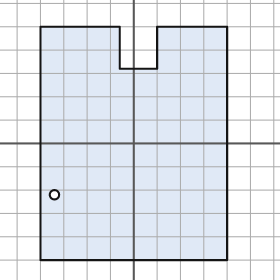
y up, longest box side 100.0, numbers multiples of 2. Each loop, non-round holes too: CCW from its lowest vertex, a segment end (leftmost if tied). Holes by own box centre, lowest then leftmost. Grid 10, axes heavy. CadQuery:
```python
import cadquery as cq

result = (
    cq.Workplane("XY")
    .moveTo(-40.0, -50.0)
    .lineTo(40.0, -50.0)
    .lineTo(40.0, 50.0)
    .lineTo(10.0, 50.0)
    .lineTo(10.0, 32.0)
    .lineTo(-6.0, 32.0)
    .lineTo(-6.0, 50.0)
    .lineTo(-40.0, 50.0)
    .close()
    .moveTo(-34.0, -22.0)
    .circle(2.0)
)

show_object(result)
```